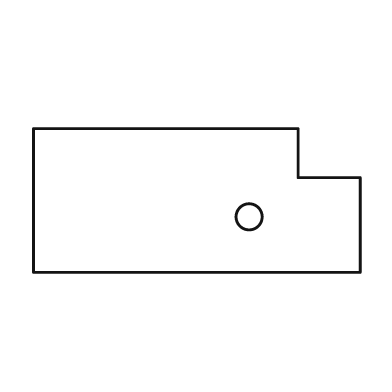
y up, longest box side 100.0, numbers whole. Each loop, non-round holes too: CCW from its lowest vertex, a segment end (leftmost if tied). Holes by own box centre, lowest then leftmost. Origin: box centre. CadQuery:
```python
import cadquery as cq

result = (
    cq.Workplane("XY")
    .moveTo(-50.0, -22.0)
    .lineTo(50.0, -22.0)
    .lineTo(50.0, 7.0)
    .lineTo(31.0, 7.0)
    .lineTo(31.0, 22.0)
    .lineTo(-50.0, 22.0)
    .close()
    .moveTo(16.0, -5.0)
    .circle(4.0)
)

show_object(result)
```